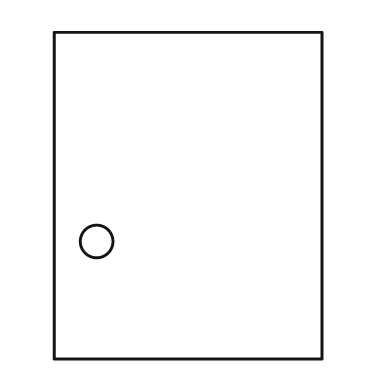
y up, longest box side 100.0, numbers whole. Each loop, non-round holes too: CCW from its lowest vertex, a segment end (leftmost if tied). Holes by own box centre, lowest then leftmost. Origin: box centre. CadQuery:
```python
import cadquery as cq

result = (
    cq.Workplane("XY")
    .moveTo(-41.0, -50.0)
    .lineTo(41.0, -50.0)
    .lineTo(41.0, 50.0)
    .lineTo(-41.0, 50.0)
    .close()
    .moveTo(-28.0, -14.0)
    .circle(5.0)
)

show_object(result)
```